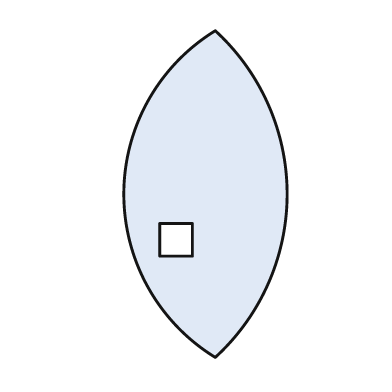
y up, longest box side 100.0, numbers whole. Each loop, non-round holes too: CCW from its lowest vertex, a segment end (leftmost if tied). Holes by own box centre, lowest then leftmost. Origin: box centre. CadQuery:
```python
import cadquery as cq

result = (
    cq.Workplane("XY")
    .moveTo(3.0, -50.0)
    .threePointArc((25.0, 0.0), (3.0, 50.0))
    .threePointArc((-25.0, 0.0), (3.0, -50.0))
    .close()
    .moveTo(-14.0, -19.0)
    .lineTo(-4.0, -19.0)
    .lineTo(-4.0, -9.0)
    .lineTo(-14.0, -9.0)
    .close()
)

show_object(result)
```